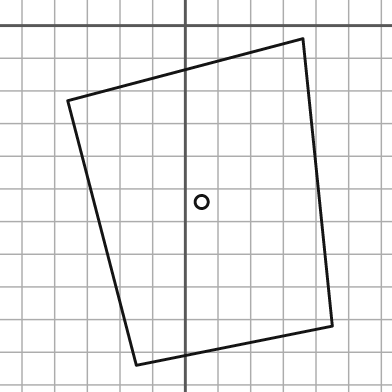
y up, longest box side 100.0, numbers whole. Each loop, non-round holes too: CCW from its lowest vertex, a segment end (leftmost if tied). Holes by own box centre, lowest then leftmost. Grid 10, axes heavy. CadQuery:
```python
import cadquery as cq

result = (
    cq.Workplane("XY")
    .moveTo(-15.0, -104.0)
    .lineTo(45.0, -92.0)
    .lineTo(36.0, -4.0)
    .lineTo(-36.0, -23.0)
    .close()
    .moveTo(5.0, -54.0)
    .circle(2.0)
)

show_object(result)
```